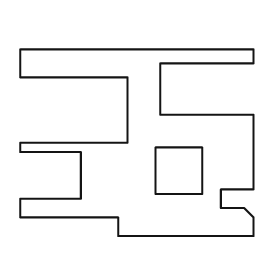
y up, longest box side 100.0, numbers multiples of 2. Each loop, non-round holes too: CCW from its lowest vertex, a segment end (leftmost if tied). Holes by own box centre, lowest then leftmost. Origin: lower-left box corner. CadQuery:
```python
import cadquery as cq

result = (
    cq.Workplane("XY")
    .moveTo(42.0, 0.0)
    .lineTo(100.0, 0.0)
    .lineTo(100.0, 8.0)
    .lineTo(96.0, 12.0)
    .lineTo(86.0, 12.0)
    .lineTo(86.0, 20.0)
    .lineTo(100.0, 20.0)
    .lineTo(100.0, 52.0)
    .lineTo(60.0, 52.0)
    .lineTo(60.0, 74.0)
    .lineTo(100.0, 74.0)
    .lineTo(100.0, 80.0)
    .lineTo(0.0, 80.0)
    .lineTo(0.0, 68.0)
    .lineTo(46.0, 68.0)
    .lineTo(46.0, 40.0)
    .lineTo(0.0, 40.0)
    .lineTo(0.0, 36.0)
    .lineTo(26.0, 36.0)
    .lineTo(26.0, 16.0)
    .lineTo(0.0, 16.0)
    .lineTo(0.0, 8.0)
    .lineTo(42.0, 8.0)
    .close()
    .moveTo(58.0, 18.0)
    .lineTo(78.0, 18.0)
    .lineTo(78.0, 38.0)
    .lineTo(58.0, 38.0)
    .close()
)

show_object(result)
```